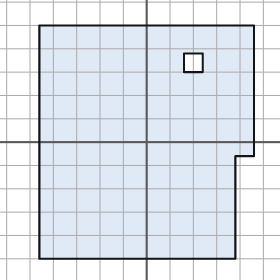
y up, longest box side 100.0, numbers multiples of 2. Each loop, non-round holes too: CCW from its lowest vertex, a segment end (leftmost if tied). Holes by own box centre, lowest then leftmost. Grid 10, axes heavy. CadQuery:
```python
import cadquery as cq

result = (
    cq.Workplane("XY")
    .moveTo(-46.0, -50.0)
    .lineTo(38.0, -50.0)
    .lineTo(38.0, -6.0)
    .lineTo(46.0, -6.0)
    .lineTo(46.0, 50.0)
    .lineTo(-46.0, 50.0)
    .close()
    .moveTo(16.0, 30.0)
    .lineTo(24.0, 30.0)
    .lineTo(24.0, 38.0)
    .lineTo(16.0, 38.0)
    .close()
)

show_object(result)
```